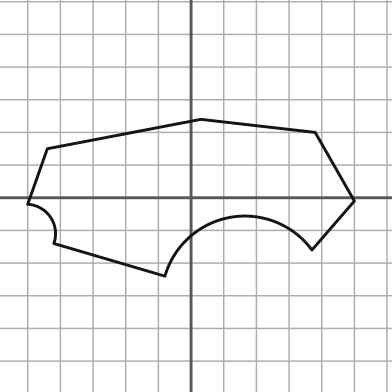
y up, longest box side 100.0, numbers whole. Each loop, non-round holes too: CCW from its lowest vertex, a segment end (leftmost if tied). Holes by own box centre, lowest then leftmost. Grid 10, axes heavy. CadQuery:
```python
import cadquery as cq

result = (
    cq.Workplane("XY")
    .moveTo(-8.0, -24.0)
    .threePointArc((12.0, -6.0), (37.0, -16.0))
    .lineTo(50.0, -1.0)
    .lineTo(38.0, 20.0)
    .lineTo(3.0, 24.0)
    .lineTo(-44.0, 15.0)
    .lineTo(-50.0, -2.0)
    .threePointArc((-43.0, -6.0), (-42.0, -14.0))
    .close()
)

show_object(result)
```